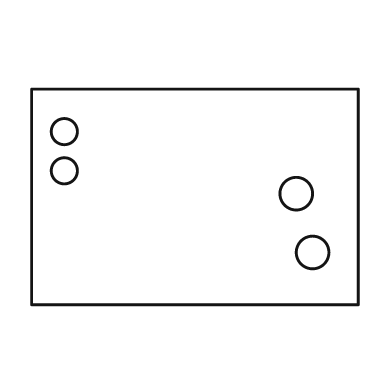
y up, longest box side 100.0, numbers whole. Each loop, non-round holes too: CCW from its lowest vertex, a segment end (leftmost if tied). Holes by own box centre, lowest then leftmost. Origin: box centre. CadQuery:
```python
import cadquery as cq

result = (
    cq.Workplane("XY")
    .moveTo(-50.0, -33.0)
    .lineTo(50.0, -33.0)
    .lineTo(50.0, 33.0)
    .lineTo(-50.0, 33.0)
    .close()
    .moveTo(36.0, -17.0)
    .circle(5.0)
    .moveTo(31.0, 1.0)
    .circle(5.0)
    .moveTo(-40.0, 8.0)
    .circle(4.0)
    .moveTo(-40.0, 20.0)
    .circle(4.0)
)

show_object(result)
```